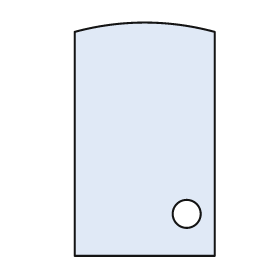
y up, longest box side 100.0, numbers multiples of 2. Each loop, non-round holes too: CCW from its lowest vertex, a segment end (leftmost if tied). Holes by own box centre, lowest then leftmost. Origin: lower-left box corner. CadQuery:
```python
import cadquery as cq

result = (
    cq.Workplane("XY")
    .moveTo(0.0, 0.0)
    .lineTo(60.0, 0.0)
    .lineTo(60.0, 96.0)
    .threePointArc((30.0, 100.0), (0.0, 96.0))
    .close()
    .moveTo(48.0, 18.0)
    .circle(6.0)
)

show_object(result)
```